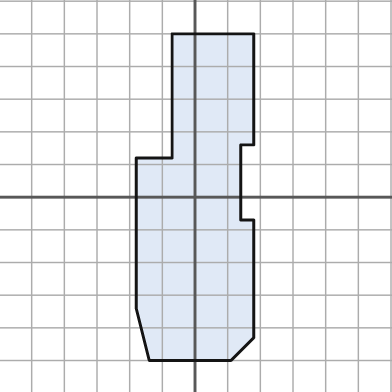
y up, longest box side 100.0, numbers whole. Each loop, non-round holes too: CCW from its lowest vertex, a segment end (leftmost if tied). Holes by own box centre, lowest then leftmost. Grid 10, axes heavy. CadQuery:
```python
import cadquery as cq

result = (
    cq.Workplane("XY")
    .moveTo(-14.0, -50.0)
    .lineTo(11.0, -50.0)
    .lineTo(18.0, -43.0)
    .lineTo(18.0, -7.0)
    .lineTo(14.0, -7.0)
    .lineTo(14.0, 16.0)
    .lineTo(18.0, 16.0)
    .lineTo(18.0, 50.0)
    .lineTo(-7.0, 50.0)
    .lineTo(-7.0, 12.0)
    .lineTo(-18.0, 12.0)
    .lineTo(-18.0, -34.0)
    .close()
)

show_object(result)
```